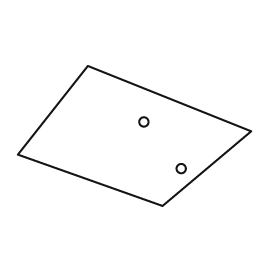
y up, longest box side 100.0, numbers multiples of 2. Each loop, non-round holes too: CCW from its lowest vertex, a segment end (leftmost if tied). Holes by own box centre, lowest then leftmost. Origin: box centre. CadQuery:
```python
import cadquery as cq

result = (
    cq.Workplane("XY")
    .moveTo(12.0, -30.0)
    .lineTo(50.0, 2.0)
    .lineTo(-20.0, 30.0)
    .lineTo(-50.0, -8.0)
    .close()
    .moveTo(20.0, -14.0)
    .circle(2.0)
    .moveTo(4.0, 6.0)
    .circle(2.0)
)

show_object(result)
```